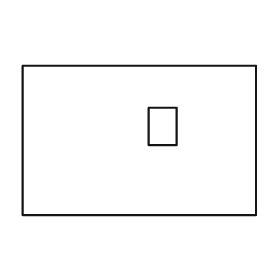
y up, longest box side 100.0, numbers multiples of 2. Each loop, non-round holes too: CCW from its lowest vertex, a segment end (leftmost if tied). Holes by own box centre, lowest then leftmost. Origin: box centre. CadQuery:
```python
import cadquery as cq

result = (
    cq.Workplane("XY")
    .moveTo(-50.0, -32.0)
    .lineTo(50.0, -32.0)
    .lineTo(50.0, 32.0)
    .lineTo(-50.0, 32.0)
    .close()
    .moveTo(4.0, -2.0)
    .lineTo(16.0, -2.0)
    .lineTo(16.0, 14.0)
    .lineTo(4.0, 14.0)
    .close()
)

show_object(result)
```